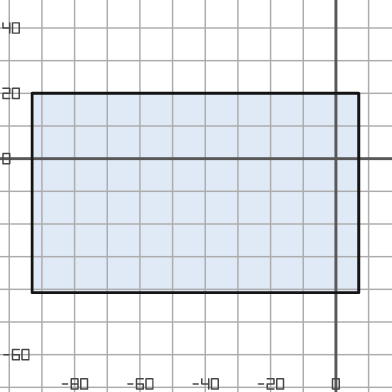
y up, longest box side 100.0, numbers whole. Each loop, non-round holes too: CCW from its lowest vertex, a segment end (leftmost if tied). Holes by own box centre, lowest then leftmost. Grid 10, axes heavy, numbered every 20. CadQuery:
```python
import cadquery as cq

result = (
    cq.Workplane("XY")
    .moveTo(-93.0, -41.0)
    .lineTo(7.0, -41.0)
    .lineTo(7.0, 20.0)
    .lineTo(-93.0, 20.0)
    .close()
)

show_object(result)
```